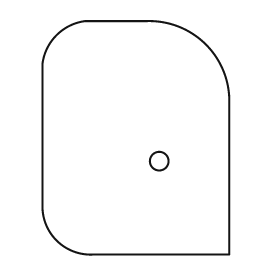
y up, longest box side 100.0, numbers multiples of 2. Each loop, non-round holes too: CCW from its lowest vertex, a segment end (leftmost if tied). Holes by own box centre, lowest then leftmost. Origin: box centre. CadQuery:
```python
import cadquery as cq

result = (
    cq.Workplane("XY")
    .moveTo(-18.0, -50.0)
    .lineTo(40.0, -50.0)
    .lineTo(40.0, 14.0)
    .threePointArc((30.0, 40.0), (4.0, 50.0))
    .lineTo(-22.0, 50.0)
    .threePointArc((-34.0, 44.0), (-40.0, 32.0))
    .lineTo(-40.0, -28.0)
    .threePointArc((-34.0, -44.0), (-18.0, -50.0))
    .close()
    .moveTo(10.0, -10.0)
    .circle(4.0)
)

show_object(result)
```